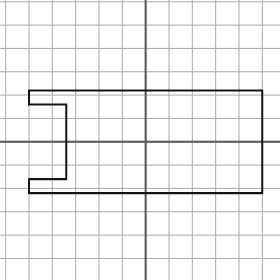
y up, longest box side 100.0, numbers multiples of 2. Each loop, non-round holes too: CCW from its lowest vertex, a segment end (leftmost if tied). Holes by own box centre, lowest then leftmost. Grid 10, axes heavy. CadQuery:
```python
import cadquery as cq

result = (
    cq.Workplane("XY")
    .moveTo(-50.0, -22.0)
    .lineTo(50.0, -22.0)
    .lineTo(50.0, 22.0)
    .lineTo(-50.0, 22.0)
    .lineTo(-50.0, 16.0)
    .lineTo(-34.0, 16.0)
    .lineTo(-34.0, -16.0)
    .lineTo(-50.0, -16.0)
    .close()
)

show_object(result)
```